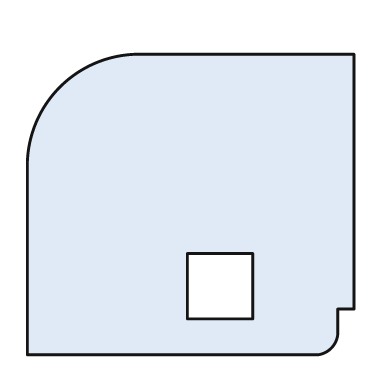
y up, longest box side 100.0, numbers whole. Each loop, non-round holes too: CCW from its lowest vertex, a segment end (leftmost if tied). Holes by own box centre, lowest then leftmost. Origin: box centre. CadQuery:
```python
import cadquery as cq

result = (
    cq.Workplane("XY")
    .moveTo(-50.0, -46.0)
    .lineTo(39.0, -46.0)
    .threePointArc((43.0, -44.0), (45.0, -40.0))
    .lineTo(45.0, -32.0)
    .lineTo(50.0, -32.0)
    .lineTo(50.0, 46.0)
    .lineTo(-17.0, 46.0)
    .threePointArc((-40.0, 36.0), (-50.0, 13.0))
    .close()
    .moveTo(-1.0, -35.0)
    .lineTo(19.0, -35.0)
    .lineTo(19.0, -15.0)
    .lineTo(-1.0, -15.0)
    .close()
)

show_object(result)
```